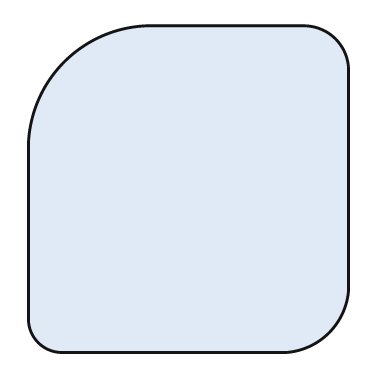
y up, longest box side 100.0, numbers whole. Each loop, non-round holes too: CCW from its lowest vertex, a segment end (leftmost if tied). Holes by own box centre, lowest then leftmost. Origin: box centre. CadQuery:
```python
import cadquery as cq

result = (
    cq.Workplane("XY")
    .moveTo(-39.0, -50.0)
    .lineTo(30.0, -50.0)
    .threePointArc((43.0, -44.0), (49.0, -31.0))
    .lineTo(49.0, 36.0)
    .threePointArc((45.0, 46.0), (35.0, 50.0))
    .lineTo(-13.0, 50.0)
    .threePointArc((-38.0, 39.0), (-49.0, 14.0))
    .lineTo(-49.0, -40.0)
    .threePointArc((-46.0, -47.0), (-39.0, -50.0))
    .close()
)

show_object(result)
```